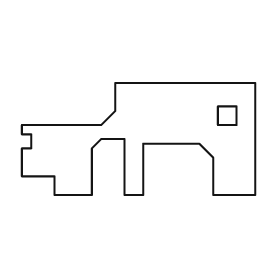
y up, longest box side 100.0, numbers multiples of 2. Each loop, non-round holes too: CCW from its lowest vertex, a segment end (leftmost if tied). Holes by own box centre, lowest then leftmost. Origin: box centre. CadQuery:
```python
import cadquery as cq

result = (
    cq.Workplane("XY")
    .moveTo(-36.0, -24.0)
    .lineTo(-20.0, -24.0)
    .lineTo(-20.0, -4.0)
    .lineTo(-16.0, 0.0)
    .lineTo(-6.0, 0.0)
    .lineTo(-6.0, -24.0)
    .lineTo(2.0, -24.0)
    .lineTo(2.0, -2.0)
    .lineTo(26.0, -2.0)
    .lineTo(32.0, -8.0)
    .lineTo(32.0, -24.0)
    .lineTo(50.0, -24.0)
    .lineTo(50.0, 24.0)
    .lineTo(-10.0, 24.0)
    .lineTo(-10.0, 12.0)
    .lineTo(-16.0, 6.0)
    .lineTo(-50.0, 6.0)
    .lineTo(-50.0, 2.0)
    .lineTo(-46.0, 2.0)
    .lineTo(-46.0, -4.0)
    .lineTo(-50.0, -4.0)
    .lineTo(-50.0, -16.0)
    .lineTo(-36.0, -16.0)
    .close()
    .moveTo(34.0, 6.0)
    .lineTo(42.0, 6.0)
    .lineTo(42.0, 14.0)
    .lineTo(34.0, 14.0)
    .close()
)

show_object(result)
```